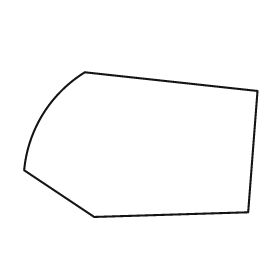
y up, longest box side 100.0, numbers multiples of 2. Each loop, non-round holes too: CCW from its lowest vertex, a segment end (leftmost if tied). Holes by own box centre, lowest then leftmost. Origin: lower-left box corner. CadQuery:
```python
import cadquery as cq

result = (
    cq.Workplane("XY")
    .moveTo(30.0, 0.0)
    .lineTo(96.0, 2.0)
    .lineTo(100.0, 54.0)
    .lineTo(26.0, 62.0)
    .threePointArc((8.0, 44.0), (0.0, 20.0))
    .close()
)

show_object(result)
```